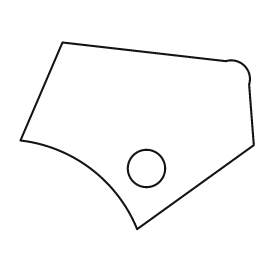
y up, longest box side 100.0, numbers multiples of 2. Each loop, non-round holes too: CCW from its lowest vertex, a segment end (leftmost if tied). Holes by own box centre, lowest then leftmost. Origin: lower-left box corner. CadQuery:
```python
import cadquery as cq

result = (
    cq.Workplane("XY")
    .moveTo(50.0, 0.0)
    .lineTo(100.0, 36.0)
    .lineTo(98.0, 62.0)
    .threePointArc((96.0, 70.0), (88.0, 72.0))
    .lineTo(18.0, 80.0)
    .lineTo(0.0, 38.0)
    .threePointArc((30.0, 26.0), (50.0, 0.0))
    .close()
    .moveTo(54.0, 26.0)
    .circle(8.0)
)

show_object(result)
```